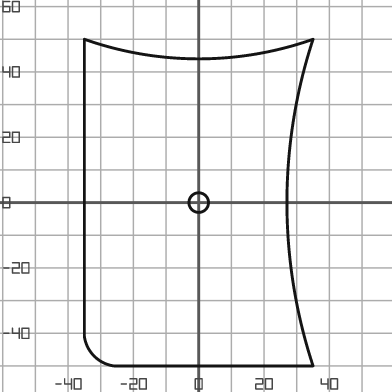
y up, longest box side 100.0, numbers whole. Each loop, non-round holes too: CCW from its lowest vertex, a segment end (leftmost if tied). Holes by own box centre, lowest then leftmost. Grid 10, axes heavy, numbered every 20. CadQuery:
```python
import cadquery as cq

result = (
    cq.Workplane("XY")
    .moveTo(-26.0, -50.0)
    .lineTo(35.0, -50.0)
    .threePointArc((27.0, 0.0), (35.0, 50.0))
    .threePointArc((0.0, 44.0), (-35.0, 50.0))
    .lineTo(-35.0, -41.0)
    .threePointArc((-32.0, -47.0), (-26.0, -50.0))
    .close()
    .moveTo(0.0, 0.0)
    .circle(3.0)
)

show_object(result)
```